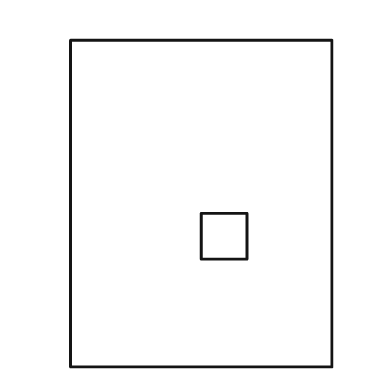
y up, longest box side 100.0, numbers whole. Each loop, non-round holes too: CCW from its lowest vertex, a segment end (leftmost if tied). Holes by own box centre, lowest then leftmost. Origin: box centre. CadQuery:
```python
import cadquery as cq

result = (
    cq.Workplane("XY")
    .moveTo(-40.0, -50.0)
    .lineTo(40.0, -50.0)
    .lineTo(40.0, 50.0)
    .lineTo(-40.0, 50.0)
    .close()
    .moveTo(0.0, -17.0)
    .lineTo(14.0, -17.0)
    .lineTo(14.0, -3.0)
    .lineTo(0.0, -3.0)
    .close()
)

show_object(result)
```